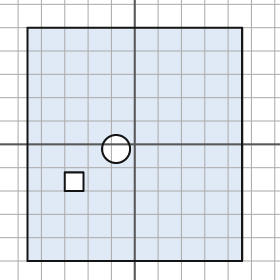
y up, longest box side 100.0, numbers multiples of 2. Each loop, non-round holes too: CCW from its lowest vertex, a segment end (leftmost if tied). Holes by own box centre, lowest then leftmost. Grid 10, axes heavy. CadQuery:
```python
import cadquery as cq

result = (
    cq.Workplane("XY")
    .moveTo(-46.0, -50.0)
    .lineTo(46.0, -50.0)
    .lineTo(46.0, 50.0)
    .lineTo(-46.0, 50.0)
    .close()
    .moveTo(-30.0, -20.0)
    .lineTo(-22.0, -20.0)
    .lineTo(-22.0, -12.0)
    .lineTo(-30.0, -12.0)
    .close()
    .moveTo(-8.0, -2.0)
    .circle(6.0)
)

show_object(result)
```